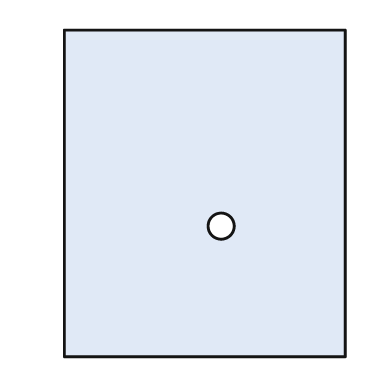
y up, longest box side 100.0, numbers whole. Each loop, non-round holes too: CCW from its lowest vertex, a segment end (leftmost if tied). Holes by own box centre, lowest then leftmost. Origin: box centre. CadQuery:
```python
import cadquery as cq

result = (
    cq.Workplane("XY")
    .moveTo(-43.0, -50.0)
    .lineTo(43.0, -50.0)
    .lineTo(43.0, 50.0)
    .lineTo(-43.0, 50.0)
    .close()
    .moveTo(5.0, -10.0)
    .circle(4.0)
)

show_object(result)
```